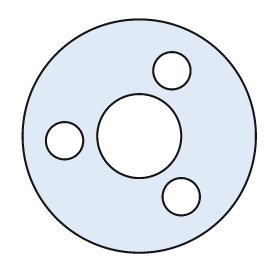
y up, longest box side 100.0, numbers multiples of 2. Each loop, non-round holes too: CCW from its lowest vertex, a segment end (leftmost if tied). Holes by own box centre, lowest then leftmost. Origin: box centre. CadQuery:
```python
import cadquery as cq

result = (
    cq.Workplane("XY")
    .moveTo(0.0, 0.0)
    .circle(50.0)
    .moveTo(18.0, -26.0)
    .circle(8.0)
    .moveTo(-32.0, -2.0)
    .circle(8.0)
    .moveTo(0.0, 0.0)
    .circle(18.0)
    .moveTo(14.0, 28.0)
    .circle(8.0)
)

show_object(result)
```